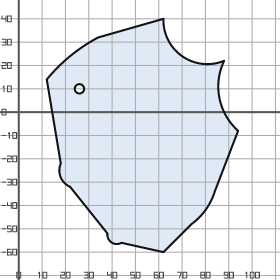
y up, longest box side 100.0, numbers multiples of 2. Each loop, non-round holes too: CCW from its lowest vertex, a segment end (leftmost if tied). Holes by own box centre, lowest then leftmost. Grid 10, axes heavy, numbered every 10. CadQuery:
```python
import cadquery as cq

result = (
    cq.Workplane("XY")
    .moveTo(62.0, -60.0)
    .lineTo(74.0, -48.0)
    .threePointArc((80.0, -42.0), (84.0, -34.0))
    .lineTo(94.0, -8.0)
    .threePointArc((86.0, 6.0), (88.0, 22.0))
    .threePointArc((70.0, 24.0), (62.0, 40.0))
    .lineTo(34.0, 32.0)
    .threePointArc((22.0, 24.0), (12.0, 14.0))
    .lineTo(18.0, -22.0)
    .threePointArc((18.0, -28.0), (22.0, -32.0))
    .lineTo(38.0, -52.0)
    .threePointArc((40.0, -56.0), (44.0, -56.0))
    .close()
    .moveTo(26.0, 10.0)
    .circle(2.0)
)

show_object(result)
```